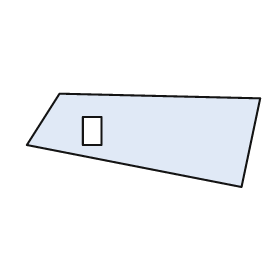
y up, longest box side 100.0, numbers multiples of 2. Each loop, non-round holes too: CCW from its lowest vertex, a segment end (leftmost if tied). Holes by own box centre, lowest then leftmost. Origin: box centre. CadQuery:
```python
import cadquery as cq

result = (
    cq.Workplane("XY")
    .moveTo(42.0, -20.0)
    .lineTo(50.0, 18.0)
    .lineTo(-36.0, 20.0)
    .lineTo(-50.0, -2.0)
    .close()
    .moveTo(-26.0, -2.0)
    .lineTo(-18.0, -2.0)
    .lineTo(-18.0, 10.0)
    .lineTo(-26.0, 10.0)
    .close()
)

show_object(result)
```